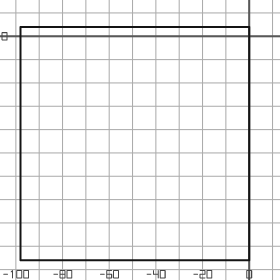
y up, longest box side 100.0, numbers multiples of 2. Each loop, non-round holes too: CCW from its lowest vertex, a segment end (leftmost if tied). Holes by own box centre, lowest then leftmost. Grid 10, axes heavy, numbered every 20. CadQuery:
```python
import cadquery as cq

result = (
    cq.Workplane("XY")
    .moveTo(-98.0, -96.0)
    .lineTo(0.0, -96.0)
    .lineTo(0.0, 4.0)
    .lineTo(-98.0, 4.0)
    .close()
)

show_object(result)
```